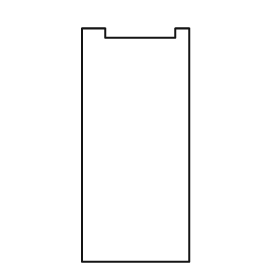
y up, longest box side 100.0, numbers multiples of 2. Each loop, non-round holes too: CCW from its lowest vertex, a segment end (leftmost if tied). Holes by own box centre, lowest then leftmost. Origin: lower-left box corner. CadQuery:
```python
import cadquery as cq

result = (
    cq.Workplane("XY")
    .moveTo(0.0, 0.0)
    .lineTo(46.0, 0.0)
    .lineTo(46.0, 100.0)
    .lineTo(40.0, 100.0)
    .lineTo(40.0, 96.0)
    .lineTo(10.0, 96.0)
    .lineTo(10.0, 100.0)
    .lineTo(0.0, 100.0)
    .close()
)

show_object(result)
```